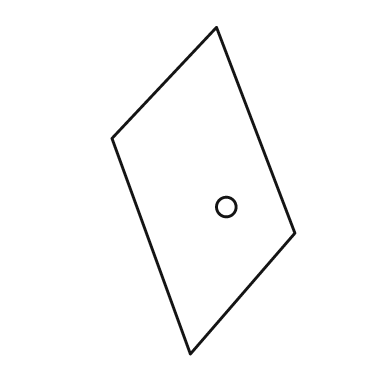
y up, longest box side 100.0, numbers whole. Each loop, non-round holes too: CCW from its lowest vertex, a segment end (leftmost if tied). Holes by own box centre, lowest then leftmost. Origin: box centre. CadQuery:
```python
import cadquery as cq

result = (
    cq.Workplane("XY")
    .moveTo(-4.0, -50.0)
    .lineTo(28.0, -13.0)
    .lineTo(4.0, 50.0)
    .lineTo(-28.0, 16.0)
    .close()
    .moveTo(7.0, -5.0)
    .circle(3.0)
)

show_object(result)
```